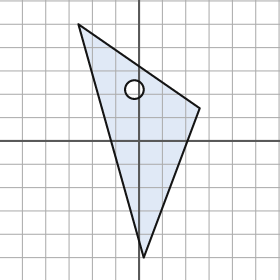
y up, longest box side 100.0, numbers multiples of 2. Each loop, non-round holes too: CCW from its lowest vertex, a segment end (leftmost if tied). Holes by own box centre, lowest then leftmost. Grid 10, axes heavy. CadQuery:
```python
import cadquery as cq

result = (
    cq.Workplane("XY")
    .moveTo(2.0, -50.0)
    .lineTo(26.0, 14.0)
    .lineTo(-26.0, 50.0)
    .close()
    .moveTo(-2.0, 22.0)
    .circle(4.0)
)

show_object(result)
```